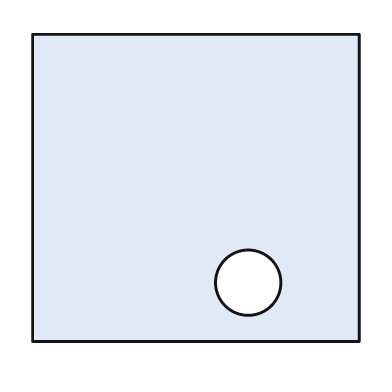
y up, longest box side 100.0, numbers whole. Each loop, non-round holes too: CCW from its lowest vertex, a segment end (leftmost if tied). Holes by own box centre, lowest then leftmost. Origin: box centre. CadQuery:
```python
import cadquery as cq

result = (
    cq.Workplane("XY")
    .moveTo(-50.0, -47.0)
    .lineTo(50.0, -47.0)
    .lineTo(50.0, 47.0)
    .lineTo(-50.0, 47.0)
    .close()
    .moveTo(16.0, -29.0)
    .circle(10.0)
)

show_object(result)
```